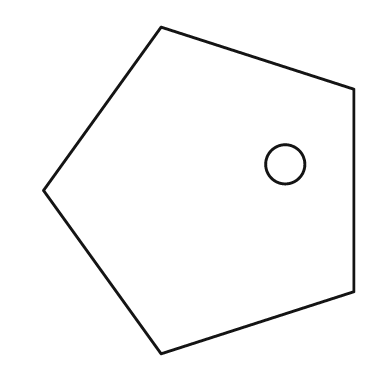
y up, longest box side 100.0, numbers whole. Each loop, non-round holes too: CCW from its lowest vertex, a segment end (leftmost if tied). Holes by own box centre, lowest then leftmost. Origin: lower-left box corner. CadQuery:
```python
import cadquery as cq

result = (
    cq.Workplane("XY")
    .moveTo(36.0, 0.0)
    .lineTo(95.0, 19.0)
    .lineTo(95.0, 81.0)
    .lineTo(36.0, 100.0)
    .lineTo(0.0, 50.0)
    .close()
    .moveTo(74.0, 58.0)
    .circle(6.0)
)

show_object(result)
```